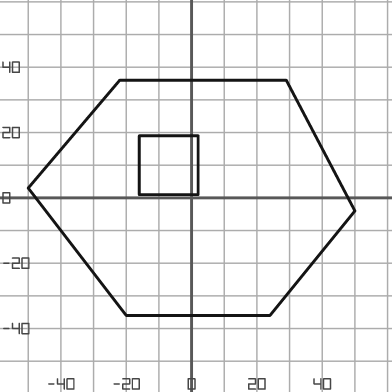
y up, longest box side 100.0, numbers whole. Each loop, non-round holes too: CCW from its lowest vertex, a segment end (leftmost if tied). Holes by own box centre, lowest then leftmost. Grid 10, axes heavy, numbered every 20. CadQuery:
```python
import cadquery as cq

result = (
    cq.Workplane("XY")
    .moveTo(-20.0, -36.0)
    .lineTo(24.0, -36.0)
    .lineTo(50.0, -4.0)
    .lineTo(29.0, 36.0)
    .lineTo(-22.0, 36.0)
    .lineTo(-50.0, 3.0)
    .close()
    .moveTo(-16.0, 1.0)
    .lineTo(2.0, 1.0)
    .lineTo(2.0, 19.0)
    .lineTo(-16.0, 19.0)
    .close()
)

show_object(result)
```